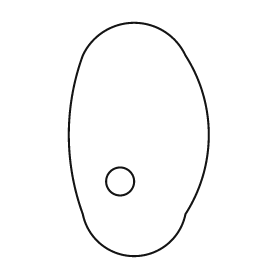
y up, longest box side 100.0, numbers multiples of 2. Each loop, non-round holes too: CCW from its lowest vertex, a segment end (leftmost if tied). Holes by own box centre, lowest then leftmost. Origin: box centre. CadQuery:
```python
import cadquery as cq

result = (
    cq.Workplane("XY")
    .moveTo(-24.0, -32.0)
    .threePointArc((-2.0, -50.0), (20.0, -32.0))
    .threePointArc((30.0, 2.0), (20.0, 36.0))
    .threePointArc((-2.0, 50.0), (-24.0, 36.0))
    .threePointArc((-30.0, 2.0), (-24.0, -32.0))
    .close()
    .moveTo(-8.0, -18.0)
    .circle(6.0)
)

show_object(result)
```